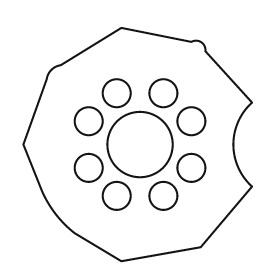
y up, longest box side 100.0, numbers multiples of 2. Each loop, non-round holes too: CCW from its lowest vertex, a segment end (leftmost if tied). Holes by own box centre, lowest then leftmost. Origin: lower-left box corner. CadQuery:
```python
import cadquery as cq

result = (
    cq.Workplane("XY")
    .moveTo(42.0, 0.0)
    .lineTo(76.0, 6.0)
    .lineTo(98.0, 32.0)
    .threePointArc((90.0, 50.0), (98.0, 68.0))
    .lineTo(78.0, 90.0)
    .threePointArc((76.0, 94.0), (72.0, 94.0))
    .lineTo(42.0, 100.0)
    .lineTo(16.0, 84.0)
    .threePointArc((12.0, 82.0), (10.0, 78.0))
    .lineTo(0.0, 50.0)
    .lineTo(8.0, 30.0)
    .threePointArc((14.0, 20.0), (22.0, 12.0))
    .close()
    .moveTo(40.0, 28.0)
    .circle(6.0)
    .moveTo(60.0, 28.0)
    .circle(6.0)
    .moveTo(28.0, 40.0)
    .circle(6.0)
    .moveTo(72.0, 40.0)
    .circle(6.0)
    .moveTo(50.0, 50.0)
    .circle(14.0)
    .moveTo(28.0, 60.0)
    .circle(6.0)
    .moveTo(72.0, 60.0)
    .circle(6.0)
    .moveTo(40.0, 72.0)
    .circle(6.0)
    .moveTo(60.0, 72.0)
    .circle(6.0)
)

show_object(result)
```